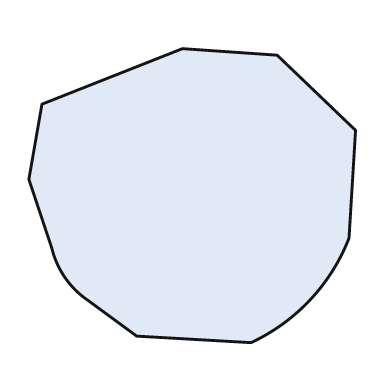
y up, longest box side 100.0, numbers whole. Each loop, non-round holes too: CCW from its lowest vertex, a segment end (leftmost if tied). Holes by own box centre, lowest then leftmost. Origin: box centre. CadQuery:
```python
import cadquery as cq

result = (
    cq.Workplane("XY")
    .moveTo(18.0, -45.0)
    .threePointArc((36.0, -32.0), (48.0, -13.0))
    .lineTo(50.0, 20.0)
    .lineTo(26.0, 43.0)
    .lineTo(-3.0, 45.0)
    .lineTo(-46.0, 28.0)
    .lineTo(-50.0, 5.0)
    .lineTo(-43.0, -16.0)
    .threePointArc((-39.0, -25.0), (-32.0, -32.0))
    .lineTo(-17.0, -43.0)
    .close()
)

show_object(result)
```